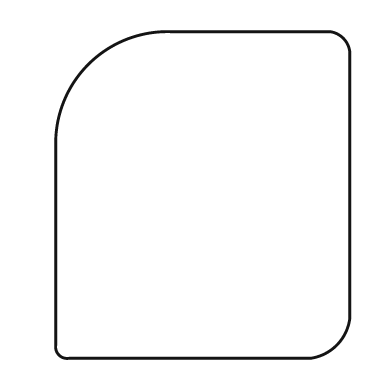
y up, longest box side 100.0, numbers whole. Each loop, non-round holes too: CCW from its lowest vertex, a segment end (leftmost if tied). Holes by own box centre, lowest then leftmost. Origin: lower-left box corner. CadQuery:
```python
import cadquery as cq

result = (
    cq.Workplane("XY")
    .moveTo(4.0, 0.0)
    .lineTo(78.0, 0.0)
    .threePointArc((86.0, 4.0), (90.0, 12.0))
    .lineTo(90.0, 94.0)
    .threePointArc((88.0, 98.0), (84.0, 100.0))
    .lineTo(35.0, 100.0)
    .threePointArc((10.0, 90.0), (0.0, 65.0))
    .lineTo(0.0, 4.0)
    .threePointArc((1.0, 1.0), (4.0, 0.0))
    .close()
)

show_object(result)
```